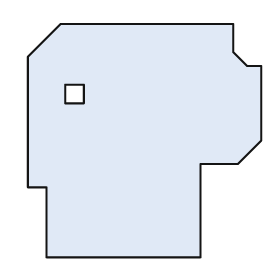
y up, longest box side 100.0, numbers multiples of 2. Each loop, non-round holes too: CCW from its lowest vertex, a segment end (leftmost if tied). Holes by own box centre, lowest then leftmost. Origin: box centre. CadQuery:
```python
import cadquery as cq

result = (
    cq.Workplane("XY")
    .moveTo(-42.0, -50.0)
    .lineTo(24.0, -50.0)
    .lineTo(24.0, -10.0)
    .lineTo(40.0, -10.0)
    .lineTo(50.0, 0.0)
    .lineTo(50.0, 32.0)
    .lineTo(44.0, 32.0)
    .lineTo(38.0, 38.0)
    .lineTo(38.0, 50.0)
    .lineTo(-36.0, 50.0)
    .lineTo(-50.0, 36.0)
    .lineTo(-50.0, -20.0)
    .lineTo(-42.0, -20.0)
    .close()
    .moveTo(-34.0, 16.0)
    .lineTo(-26.0, 16.0)
    .lineTo(-26.0, 24.0)
    .lineTo(-34.0, 24.0)
    .close()
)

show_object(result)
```